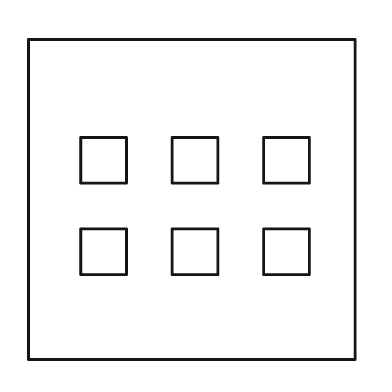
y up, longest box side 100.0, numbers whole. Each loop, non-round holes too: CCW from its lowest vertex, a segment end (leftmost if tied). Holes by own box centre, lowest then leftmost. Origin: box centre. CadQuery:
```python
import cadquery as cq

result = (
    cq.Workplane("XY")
    .moveTo(-50.0, -49.0)
    .lineTo(50.0, -49.0)
    .lineTo(50.0, 49.0)
    .lineTo(-50.0, 49.0)
    .close()
    .moveTo(-34.0, -23.0)
    .lineTo(-20.0, -23.0)
    .lineTo(-20.0, -9.0)
    .lineTo(-34.0, -9.0)
    .close()
    .moveTo(-6.0, -23.0)
    .lineTo(8.0, -23.0)
    .lineTo(8.0, -9.0)
    .lineTo(-6.0, -9.0)
    .close()
    .moveTo(22.0, -23.0)
    .lineTo(36.0, -23.0)
    .lineTo(36.0, -9.0)
    .lineTo(22.0, -9.0)
    .close()
    .moveTo(-34.0, 5.0)
    .lineTo(-20.0, 5.0)
    .lineTo(-20.0, 19.0)
    .lineTo(-34.0, 19.0)
    .close()
    .moveTo(-6.0, 5.0)
    .lineTo(8.0, 5.0)
    .lineTo(8.0, 19.0)
    .lineTo(-6.0, 19.0)
    .close()
    .moveTo(22.0, 5.0)
    .lineTo(36.0, 5.0)
    .lineTo(36.0, 19.0)
    .lineTo(22.0, 19.0)
    .close()
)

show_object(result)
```